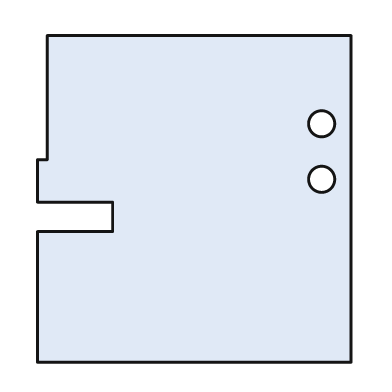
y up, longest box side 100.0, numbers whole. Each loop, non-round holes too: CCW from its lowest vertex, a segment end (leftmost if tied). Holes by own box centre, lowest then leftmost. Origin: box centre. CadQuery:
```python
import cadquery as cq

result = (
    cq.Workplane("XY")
    .moveTo(-48.0, -50.0)
    .lineTo(48.0, -50.0)
    .lineTo(48.0, 50.0)
    .lineTo(-45.0, 50.0)
    .lineTo(-45.0, 12.0)
    .lineTo(-48.0, 12.0)
    .lineTo(-48.0, -1.0)
    .lineTo(-25.0, -1.0)
    .lineTo(-25.0, -10.0)
    .lineTo(-48.0, -10.0)
    .close()
    .moveTo(39.0, 6.0)
    .circle(4.0)
    .moveTo(39.0, 23.0)
    .circle(4.0)
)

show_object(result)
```